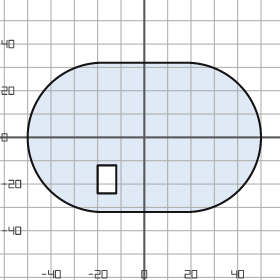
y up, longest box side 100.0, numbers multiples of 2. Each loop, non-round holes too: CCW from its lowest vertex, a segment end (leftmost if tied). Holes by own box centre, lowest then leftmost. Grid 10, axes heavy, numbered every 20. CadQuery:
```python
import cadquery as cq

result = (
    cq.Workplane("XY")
    .moveTo(-18.0, -32.0)
    .lineTo(18.0, -32.0)
    .threePointArc((50.0, 0.0), (18.0, 32.0))
    .lineTo(-18.0, 32.0)
    .threePointArc((-50.0, 0.0), (-18.0, -32.0))
    .close()
    .moveTo(-20.0, -24.0)
    .lineTo(-12.0, -24.0)
    .lineTo(-12.0, -12.0)
    .lineTo(-20.0, -12.0)
    .close()
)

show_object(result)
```